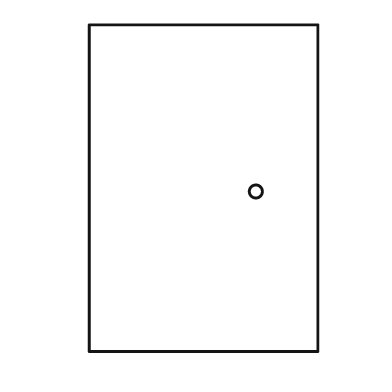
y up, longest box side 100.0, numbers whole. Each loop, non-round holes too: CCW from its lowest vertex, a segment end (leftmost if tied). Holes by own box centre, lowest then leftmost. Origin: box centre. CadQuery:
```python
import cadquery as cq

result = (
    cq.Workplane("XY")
    .moveTo(-35.0, -50.0)
    .lineTo(35.0, -50.0)
    .lineTo(35.0, 50.0)
    .lineTo(-35.0, 50.0)
    .close()
    .moveTo(16.0, -1.0)
    .circle(2.0)
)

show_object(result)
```